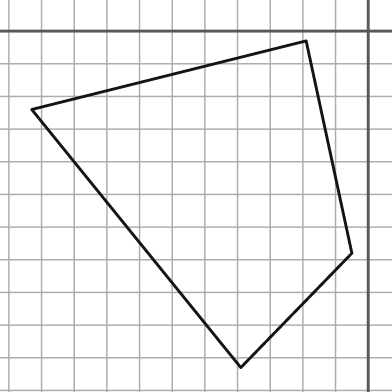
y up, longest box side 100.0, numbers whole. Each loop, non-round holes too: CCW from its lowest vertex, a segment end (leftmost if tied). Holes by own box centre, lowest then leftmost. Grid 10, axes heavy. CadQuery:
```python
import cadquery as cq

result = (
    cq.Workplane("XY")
    .moveTo(-39.0, -103.0)
    .lineTo(-5.0, -68.0)
    .lineTo(-19.0, -3.0)
    .lineTo(-103.0, -24.0)
    .close()
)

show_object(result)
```